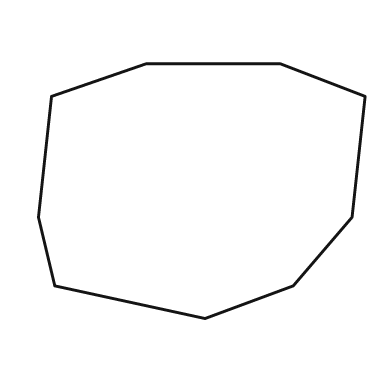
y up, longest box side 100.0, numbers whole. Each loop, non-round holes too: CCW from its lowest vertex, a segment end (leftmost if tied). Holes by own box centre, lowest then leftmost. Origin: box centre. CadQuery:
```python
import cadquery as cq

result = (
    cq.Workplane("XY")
    .moveTo(1.0, -39.0)
    .lineTo(28.0, -29.0)
    .lineTo(46.0, -8.0)
    .lineTo(50.0, 29.0)
    .lineTo(24.0, 39.0)
    .lineTo(-17.0, 39.0)
    .lineTo(-46.0, 29.0)
    .lineTo(-50.0, -8.0)
    .lineTo(-45.0, -29.0)
    .close()
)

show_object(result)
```